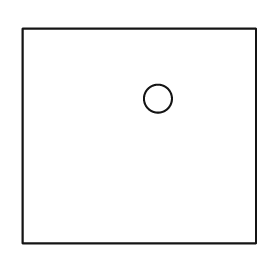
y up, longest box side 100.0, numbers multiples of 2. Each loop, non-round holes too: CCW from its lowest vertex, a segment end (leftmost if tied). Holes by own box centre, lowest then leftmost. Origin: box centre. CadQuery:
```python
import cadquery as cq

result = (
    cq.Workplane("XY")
    .moveTo(-50.0, -46.0)
    .lineTo(50.0, -46.0)
    .lineTo(50.0, 46.0)
    .lineTo(-50.0, 46.0)
    .close()
    .moveTo(8.0, 16.0)
    .circle(6.0)
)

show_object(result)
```